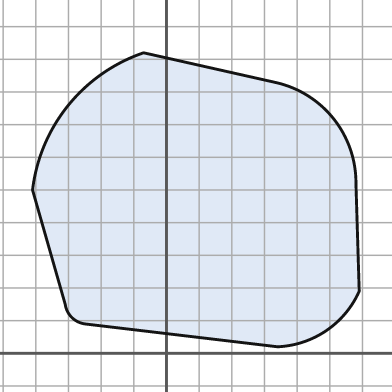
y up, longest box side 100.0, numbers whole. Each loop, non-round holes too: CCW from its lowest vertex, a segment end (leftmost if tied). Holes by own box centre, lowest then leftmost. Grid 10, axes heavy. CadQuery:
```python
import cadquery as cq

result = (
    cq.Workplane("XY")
    .moveTo(34.0, 2.0)
    .threePointArc((49.0, 7.0), (59.0, 19.0))
    .lineTo(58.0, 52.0)
    .threePointArc((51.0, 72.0), (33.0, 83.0))
    .lineTo(-7.0, 92.0)
    .threePointArc((-30.0, 76.0), (-41.0, 50.0))
    .lineTo(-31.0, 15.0)
    .threePointArc((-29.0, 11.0), (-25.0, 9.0))
    .close()
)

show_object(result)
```